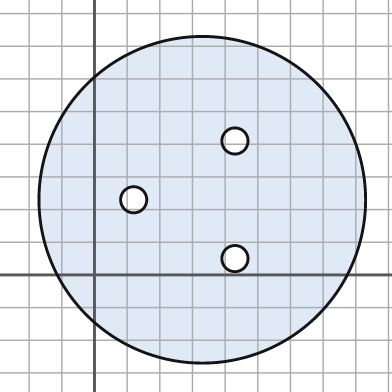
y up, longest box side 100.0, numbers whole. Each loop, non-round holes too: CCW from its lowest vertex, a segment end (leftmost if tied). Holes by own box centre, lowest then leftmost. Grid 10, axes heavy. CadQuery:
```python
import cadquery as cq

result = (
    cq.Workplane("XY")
    .moveTo(33.0, 23.0)
    .circle(50.0)
    .moveTo(43.0, 5.0)
    .circle(4.0)
    .moveTo(12.0, 23.0)
    .circle(4.0)
    .moveTo(43.0, 41.0)
    .circle(4.0)
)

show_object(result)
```